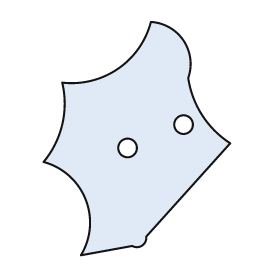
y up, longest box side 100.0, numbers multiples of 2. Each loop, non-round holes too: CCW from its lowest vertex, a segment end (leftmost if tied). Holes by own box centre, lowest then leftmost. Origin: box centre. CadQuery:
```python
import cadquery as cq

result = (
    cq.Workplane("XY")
    .moveTo(-24.0, -50.0)
    .lineTo(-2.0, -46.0)
    .threePointArc((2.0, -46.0), (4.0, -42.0))
    .lineTo(40.0, -2.0)
    .threePointArc((28.0, 10.0), (22.0, 26.0))
    .threePointArc((20.0, 42.0), (6.0, 50.0))
    .threePointArc((-8.0, 30.0), (-32.0, 24.0))
    .threePointArc((-32.0, 6.0), (-40.0, -10.0))
    .threePointArc((-22.0, -26.0), (-24.0, -50.0))
    .close()
    .moveTo(-4.0, -4.0)
    .circle(4.0)
    .moveTo(20.0, 6.0)
    .circle(4.0)
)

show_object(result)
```